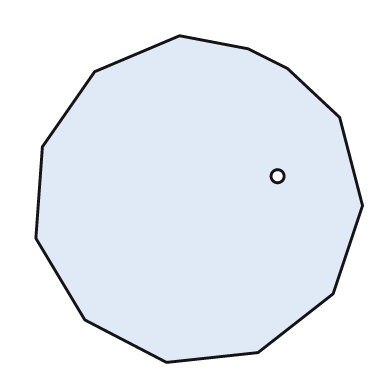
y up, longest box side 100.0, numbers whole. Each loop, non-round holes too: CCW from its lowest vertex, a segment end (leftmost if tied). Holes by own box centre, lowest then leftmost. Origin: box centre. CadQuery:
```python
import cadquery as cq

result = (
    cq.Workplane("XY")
    .moveTo(-10.0, -50.0)
    .lineTo(18.0, -47.0)
    .lineTo(41.0, -29.0)
    .lineTo(50.0, -2.0)
    .lineTo(43.0, 25.0)
    .lineTo(27.0, 40.0)
    .lineTo(15.0, 46.0)
    .lineTo(-6.0, 50.0)
    .lineTo(-32.0, 39.0)
    .lineTo(-48.0, 16.0)
    .lineTo(-50.0, -12.0)
    .lineTo(-35.0, -37.0)
    .close()
    .moveTo(24.0, 7.0)
    .circle(2.0)
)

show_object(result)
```